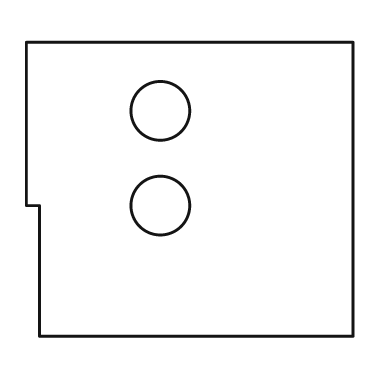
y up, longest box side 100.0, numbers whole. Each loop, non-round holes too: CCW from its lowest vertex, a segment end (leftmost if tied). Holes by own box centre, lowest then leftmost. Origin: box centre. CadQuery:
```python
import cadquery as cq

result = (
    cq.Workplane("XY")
    .moveTo(-46.0, -45.0)
    .lineTo(50.0, -45.0)
    .lineTo(50.0, 45.0)
    .lineTo(-50.0, 45.0)
    .lineTo(-50.0, -5.0)
    .lineTo(-46.0, -5.0)
    .close()
    .moveTo(-9.0, -5.0)
    .circle(9.0)
    .moveTo(-9.0, 24.0)
    .circle(9.0)
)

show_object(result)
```